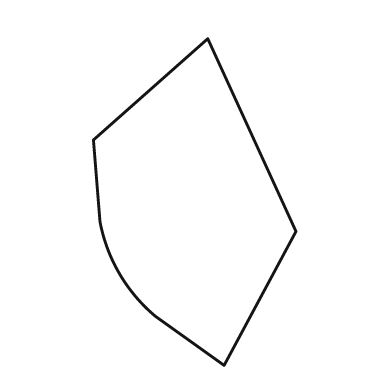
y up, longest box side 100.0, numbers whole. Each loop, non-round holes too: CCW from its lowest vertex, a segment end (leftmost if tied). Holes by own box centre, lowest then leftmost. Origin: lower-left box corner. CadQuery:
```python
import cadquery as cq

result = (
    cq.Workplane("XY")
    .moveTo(40.0, 0.0)
    .lineTo(62.0, 41.0)
    .lineTo(35.0, 100.0)
    .lineTo(0.0, 69.0)
    .lineTo(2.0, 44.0)
    .threePointArc((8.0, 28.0), (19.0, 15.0))
    .close()
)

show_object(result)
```